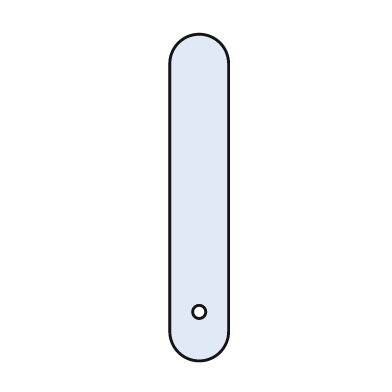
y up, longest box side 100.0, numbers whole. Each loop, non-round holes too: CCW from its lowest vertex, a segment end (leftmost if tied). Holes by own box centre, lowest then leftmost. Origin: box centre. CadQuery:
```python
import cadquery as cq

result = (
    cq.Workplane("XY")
    .moveTo(-9.0, -41.0)
    .threePointArc((0.0, -50.0), (9.0, -41.0))
    .lineTo(9.0, 41.0)
    .threePointArc((0.0, 50.0), (-9.0, 41.0))
    .close()
    .moveTo(0.0, -35.0)
    .circle(2.0)
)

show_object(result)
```